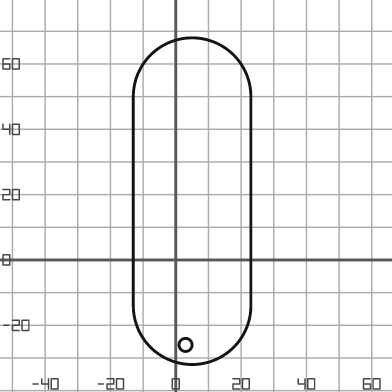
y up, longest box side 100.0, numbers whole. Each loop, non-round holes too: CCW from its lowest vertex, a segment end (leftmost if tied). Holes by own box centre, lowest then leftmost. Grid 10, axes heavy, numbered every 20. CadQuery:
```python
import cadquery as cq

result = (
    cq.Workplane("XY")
    .moveTo(-13.0, -14.0)
    .threePointArc((5.0, -32.0), (23.0, -14.0))
    .lineTo(23.0, 50.0)
    .threePointArc((5.0, 68.0), (-13.0, 50.0))
    .close()
    .moveTo(3.0, -26.0)
    .circle(2.0)
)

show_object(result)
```